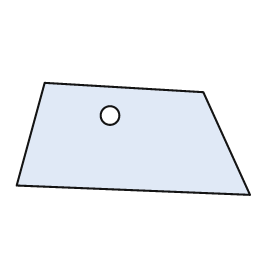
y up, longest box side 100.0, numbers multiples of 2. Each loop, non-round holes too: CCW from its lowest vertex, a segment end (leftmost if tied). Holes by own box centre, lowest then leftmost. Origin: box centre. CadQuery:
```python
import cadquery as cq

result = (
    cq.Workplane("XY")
    .moveTo(50.0, -24.0)
    .lineTo(30.0, 20.0)
    .lineTo(-38.0, 24.0)
    .lineTo(-50.0, -20.0)
    .close()
    .moveTo(-10.0, 10.0)
    .circle(4.0)
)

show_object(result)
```